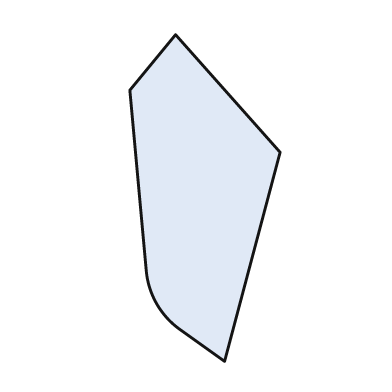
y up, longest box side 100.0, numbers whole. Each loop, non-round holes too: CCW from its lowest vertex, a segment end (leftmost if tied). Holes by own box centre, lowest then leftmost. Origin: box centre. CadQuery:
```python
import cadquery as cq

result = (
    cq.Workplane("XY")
    .moveTo(6.0, -50.0)
    .lineTo(23.0, 14.0)
    .lineTo(-9.0, 50.0)
    .lineTo(-23.0, 33.0)
    .lineTo(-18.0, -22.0)
    .threePointArc((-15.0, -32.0), (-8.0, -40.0))
    .close()
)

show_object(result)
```